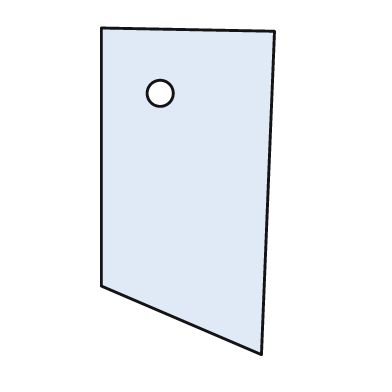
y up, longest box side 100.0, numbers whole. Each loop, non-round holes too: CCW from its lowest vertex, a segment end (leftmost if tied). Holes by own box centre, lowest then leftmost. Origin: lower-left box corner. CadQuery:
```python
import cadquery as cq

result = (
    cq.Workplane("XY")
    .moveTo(49.0, 0.0)
    .lineTo(53.0, 99.0)
    .lineTo(0.0, 100.0)
    .lineTo(0.0, 21.0)
    .close()
    .moveTo(18.0, 80.0)
    .circle(4.0)
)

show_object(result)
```